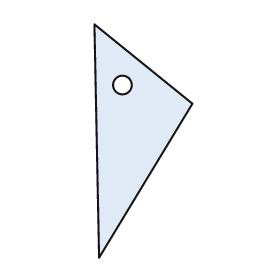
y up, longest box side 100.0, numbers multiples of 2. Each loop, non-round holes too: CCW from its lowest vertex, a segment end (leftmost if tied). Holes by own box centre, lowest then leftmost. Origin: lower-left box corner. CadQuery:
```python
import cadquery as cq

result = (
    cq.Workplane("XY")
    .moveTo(2.0, 0.0)
    .lineTo(42.0, 66.0)
    .lineTo(0.0, 100.0)
    .close()
    .moveTo(12.0, 74.0)
    .circle(4.0)
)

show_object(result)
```